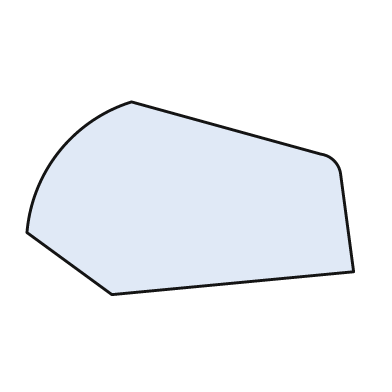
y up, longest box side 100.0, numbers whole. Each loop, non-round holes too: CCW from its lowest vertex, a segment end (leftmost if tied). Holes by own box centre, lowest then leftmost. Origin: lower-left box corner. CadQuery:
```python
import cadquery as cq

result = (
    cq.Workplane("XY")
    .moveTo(26.0, 0.0)
    .lineTo(100.0, 7.0)
    .lineTo(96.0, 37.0)
    .threePointArc((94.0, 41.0), (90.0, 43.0))
    .lineTo(32.0, 59.0)
    .threePointArc((10.0, 44.0), (0.0, 19.0))
    .close()
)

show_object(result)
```